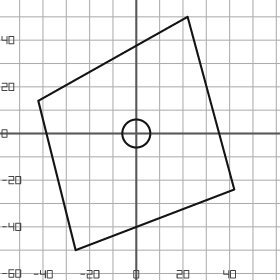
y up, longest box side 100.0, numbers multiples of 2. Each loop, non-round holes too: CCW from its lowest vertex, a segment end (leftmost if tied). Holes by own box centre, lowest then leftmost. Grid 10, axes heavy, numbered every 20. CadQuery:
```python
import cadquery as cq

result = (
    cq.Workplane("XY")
    .moveTo(-26.0, -50.0)
    .lineTo(42.0, -24.0)
    .lineTo(22.0, 50.0)
    .lineTo(-42.0, 14.0)
    .close()
    .moveTo(0.0, 0.0)
    .circle(6.0)
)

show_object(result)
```